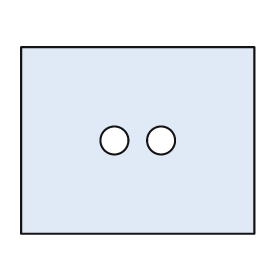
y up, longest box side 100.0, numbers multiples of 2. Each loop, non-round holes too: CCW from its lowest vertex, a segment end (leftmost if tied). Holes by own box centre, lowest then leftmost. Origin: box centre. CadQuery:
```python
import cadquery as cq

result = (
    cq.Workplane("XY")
    .moveTo(-50.0, -40.0)
    .lineTo(50.0, -40.0)
    .lineTo(50.0, 40.0)
    .lineTo(-50.0, 40.0)
    .close()
    .moveTo(-10.0, 0.0)
    .circle(6.0)
    .moveTo(10.0, 0.0)
    .circle(6.0)
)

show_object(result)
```